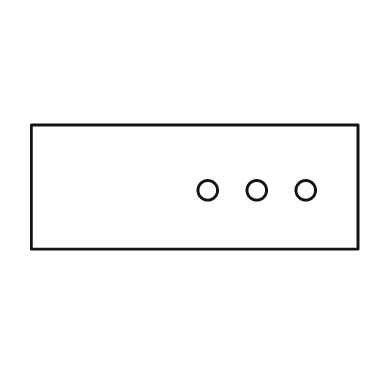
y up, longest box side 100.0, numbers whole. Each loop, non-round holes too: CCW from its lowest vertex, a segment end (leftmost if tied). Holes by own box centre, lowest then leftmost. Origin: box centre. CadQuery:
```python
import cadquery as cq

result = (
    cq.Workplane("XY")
    .moveTo(-50.0, -19.0)
    .lineTo(50.0, -19.0)
    .lineTo(50.0, 19.0)
    .lineTo(-50.0, 19.0)
    .close()
    .moveTo(4.0, -1.0)
    .circle(3.0)
    .moveTo(19.0, -1.0)
    .circle(3.0)
    .moveTo(34.0, -1.0)
    .circle(3.0)
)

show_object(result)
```